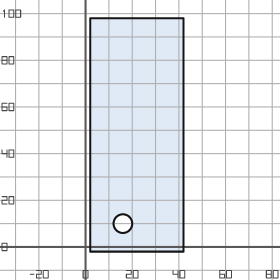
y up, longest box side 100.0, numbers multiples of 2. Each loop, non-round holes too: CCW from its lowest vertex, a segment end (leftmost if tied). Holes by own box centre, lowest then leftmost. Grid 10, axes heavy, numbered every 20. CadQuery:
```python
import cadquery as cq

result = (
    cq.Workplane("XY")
    .moveTo(2.0, -2.0)
    .lineTo(42.0, -2.0)
    .lineTo(42.0, 98.0)
    .lineTo(2.0, 98.0)
    .close()
    .moveTo(16.0, 10.0)
    .circle(4.0)
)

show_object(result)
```